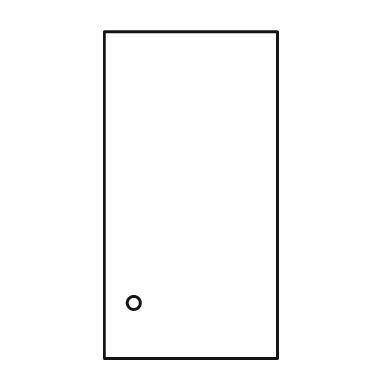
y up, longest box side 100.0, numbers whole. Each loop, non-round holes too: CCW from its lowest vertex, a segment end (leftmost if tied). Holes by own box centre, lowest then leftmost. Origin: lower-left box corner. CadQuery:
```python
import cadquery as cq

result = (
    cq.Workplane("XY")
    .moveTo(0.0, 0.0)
    .lineTo(53.0, 0.0)
    .lineTo(53.0, 100.0)
    .lineTo(0.0, 100.0)
    .close()
    .moveTo(9.0, 17.0)
    .circle(2.0)
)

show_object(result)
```